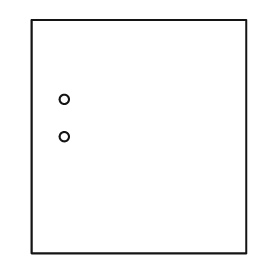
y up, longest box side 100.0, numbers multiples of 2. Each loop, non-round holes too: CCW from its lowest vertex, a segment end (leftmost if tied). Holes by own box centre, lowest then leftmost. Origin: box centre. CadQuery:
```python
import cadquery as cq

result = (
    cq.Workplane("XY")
    .moveTo(-46.0, -50.0)
    .lineTo(46.0, -50.0)
    .lineTo(46.0, 50.0)
    .lineTo(-46.0, 50.0)
    .close()
    .moveTo(-32.0, 0.0)
    .circle(2.0)
    .moveTo(-32.0, 16.0)
    .circle(2.0)
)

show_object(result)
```